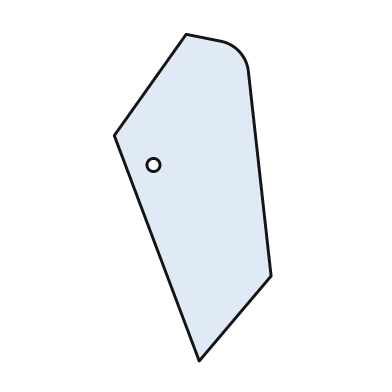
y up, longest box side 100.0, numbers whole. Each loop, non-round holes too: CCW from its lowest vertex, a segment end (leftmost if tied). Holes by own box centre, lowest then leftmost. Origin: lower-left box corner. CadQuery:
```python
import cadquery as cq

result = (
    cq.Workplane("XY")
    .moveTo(26.0, 0.0)
    .lineTo(48.0, 26.0)
    .lineTo(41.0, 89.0)
    .threePointArc((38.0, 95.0), (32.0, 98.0))
    .lineTo(22.0, 100.0)
    .lineTo(0.0, 69.0)
    .close()
    .moveTo(12.0, 60.0)
    .circle(2.0)
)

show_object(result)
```